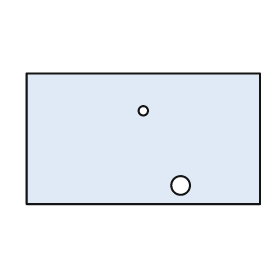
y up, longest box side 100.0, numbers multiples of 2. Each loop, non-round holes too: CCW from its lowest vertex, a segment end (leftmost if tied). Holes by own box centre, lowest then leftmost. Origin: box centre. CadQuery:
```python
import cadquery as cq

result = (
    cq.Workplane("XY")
    .moveTo(-50.0, -28.0)
    .lineTo(50.0, -28.0)
    .lineTo(50.0, 28.0)
    .lineTo(-50.0, 28.0)
    .close()
    .moveTo(16.0, -20.0)
    .circle(4.0)
    .moveTo(0.0, 12.0)
    .circle(2.0)
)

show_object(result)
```